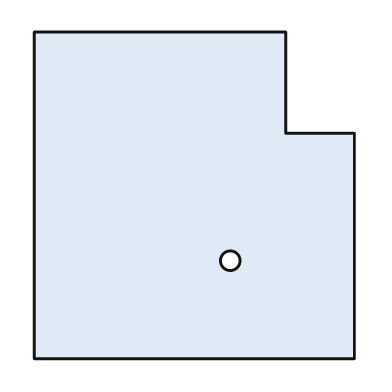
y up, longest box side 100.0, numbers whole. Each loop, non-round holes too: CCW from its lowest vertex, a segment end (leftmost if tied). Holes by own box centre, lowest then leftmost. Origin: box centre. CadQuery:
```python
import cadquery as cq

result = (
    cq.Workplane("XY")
    .moveTo(-49.0, -50.0)
    .lineTo(49.0, -50.0)
    .lineTo(49.0, 19.0)
    .lineTo(28.0, 19.0)
    .lineTo(28.0, 50.0)
    .lineTo(-49.0, 50.0)
    .close()
    .moveTo(11.0, -20.0)
    .circle(3.0)
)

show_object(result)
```